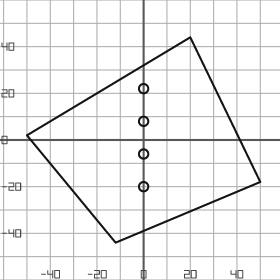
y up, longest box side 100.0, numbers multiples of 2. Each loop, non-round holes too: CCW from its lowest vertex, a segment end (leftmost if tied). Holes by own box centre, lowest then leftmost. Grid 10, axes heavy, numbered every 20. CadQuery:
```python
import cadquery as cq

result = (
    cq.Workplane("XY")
    .moveTo(-12.0, -44.0)
    .lineTo(50.0, -18.0)
    .lineTo(20.0, 44.0)
    .lineTo(-50.0, 2.0)
    .close()
    .moveTo(0.0, -20.0)
    .circle(2.0)
    .moveTo(0.0, -6.0)
    .circle(2.0)
    .moveTo(0.0, 8.0)
    .circle(2.0)
    .moveTo(0.0, 22.0)
    .circle(2.0)
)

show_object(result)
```